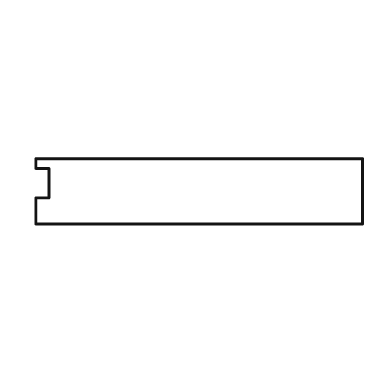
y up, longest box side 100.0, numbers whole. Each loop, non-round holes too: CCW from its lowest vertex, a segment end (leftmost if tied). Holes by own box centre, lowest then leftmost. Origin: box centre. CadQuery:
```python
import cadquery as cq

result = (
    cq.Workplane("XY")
    .moveTo(-50.0, -10.0)
    .lineTo(50.0, -10.0)
    .lineTo(50.0, 10.0)
    .lineTo(-50.0, 10.0)
    .lineTo(-50.0, 7.0)
    .lineTo(-46.0, 7.0)
    .lineTo(-46.0, -2.0)
    .lineTo(-50.0, -2.0)
    .close()
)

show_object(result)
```